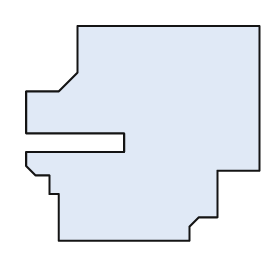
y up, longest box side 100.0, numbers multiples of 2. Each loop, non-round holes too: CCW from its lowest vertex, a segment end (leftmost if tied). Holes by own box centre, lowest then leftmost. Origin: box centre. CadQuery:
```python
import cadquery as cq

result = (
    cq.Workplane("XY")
    .moveTo(-36.0, -46.0)
    .lineTo(20.0, -46.0)
    .lineTo(20.0, -40.0)
    .lineTo(24.0, -36.0)
    .lineTo(32.0, -36.0)
    .lineTo(32.0, -16.0)
    .lineTo(50.0, -16.0)
    .lineTo(50.0, 46.0)
    .lineTo(-28.0, 46.0)
    .lineTo(-28.0, 26.0)
    .lineTo(-36.0, 18.0)
    .lineTo(-50.0, 18.0)
    .lineTo(-50.0, 0.0)
    .lineTo(-8.0, 0.0)
    .lineTo(-8.0, -8.0)
    .lineTo(-50.0, -8.0)
    .lineTo(-50.0, -14.0)
    .lineTo(-46.0, -18.0)
    .lineTo(-40.0, -18.0)
    .lineTo(-40.0, -26.0)
    .lineTo(-36.0, -26.0)
    .close()
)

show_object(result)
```